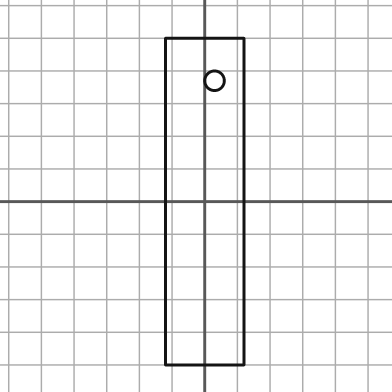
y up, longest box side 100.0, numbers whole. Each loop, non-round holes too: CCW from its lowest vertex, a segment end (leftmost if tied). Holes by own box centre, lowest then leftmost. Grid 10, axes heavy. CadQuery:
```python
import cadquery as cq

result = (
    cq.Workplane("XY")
    .moveTo(-12.0, -50.0)
    .lineTo(12.0, -50.0)
    .lineTo(12.0, 50.0)
    .lineTo(-12.0, 50.0)
    .close()
    .moveTo(3.0, 37.0)
    .circle(3.0)
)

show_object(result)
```